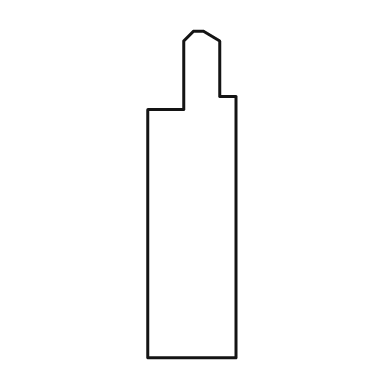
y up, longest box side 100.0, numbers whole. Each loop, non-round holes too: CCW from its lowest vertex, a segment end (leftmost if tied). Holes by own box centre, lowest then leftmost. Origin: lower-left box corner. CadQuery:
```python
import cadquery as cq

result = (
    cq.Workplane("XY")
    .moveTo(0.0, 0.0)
    .lineTo(27.0, 0.0)
    .lineTo(27.0, 80.0)
    .lineTo(22.0, 80.0)
    .lineTo(22.0, 97.0)
    .lineTo(17.0, 100.0)
    .lineTo(14.0, 100.0)
    .lineTo(11.0, 97.0)
    .lineTo(11.0, 76.0)
    .lineTo(0.0, 76.0)
    .close()
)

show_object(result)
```